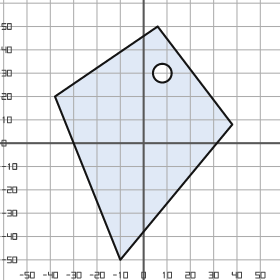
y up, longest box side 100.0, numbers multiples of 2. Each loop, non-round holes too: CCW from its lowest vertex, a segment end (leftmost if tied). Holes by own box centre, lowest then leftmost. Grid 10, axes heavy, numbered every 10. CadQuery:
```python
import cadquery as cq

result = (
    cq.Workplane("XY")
    .moveTo(-10.0, -50.0)
    .lineTo(38.0, 8.0)
    .lineTo(6.0, 50.0)
    .lineTo(-38.0, 20.0)
    .close()
    .moveTo(8.0, 30.0)
    .circle(4.0)
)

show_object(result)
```